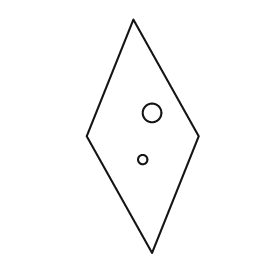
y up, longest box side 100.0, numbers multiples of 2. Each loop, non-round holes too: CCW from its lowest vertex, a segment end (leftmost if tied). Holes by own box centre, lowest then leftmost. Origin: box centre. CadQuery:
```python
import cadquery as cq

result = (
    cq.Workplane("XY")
    .moveTo(4.0, -50.0)
    .lineTo(24.0, 0.0)
    .lineTo(-4.0, 50.0)
    .lineTo(-24.0, 0.0)
    .close()
    .moveTo(0.0, -10.0)
    .circle(2.0)
    .moveTo(4.0, 10.0)
    .circle(4.0)
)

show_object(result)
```